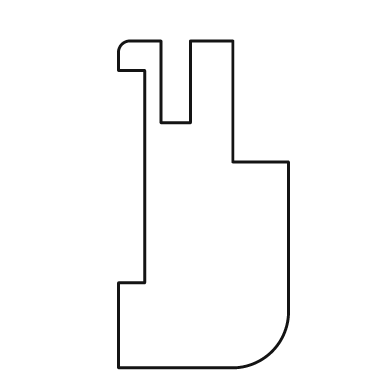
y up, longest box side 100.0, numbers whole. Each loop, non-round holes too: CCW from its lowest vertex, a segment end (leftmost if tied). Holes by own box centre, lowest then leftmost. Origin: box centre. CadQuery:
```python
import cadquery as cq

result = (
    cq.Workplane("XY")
    .moveTo(-26.0, -50.0)
    .lineTo(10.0, -50.0)
    .threePointArc((21.0, -45.0), (26.0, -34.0))
    .lineTo(26.0, 13.0)
    .lineTo(9.0, 13.0)
    .lineTo(9.0, 50.0)
    .lineTo(-4.0, 50.0)
    .lineTo(-4.0, 25.0)
    .lineTo(-13.0, 25.0)
    .lineTo(-13.0, 50.0)
    .lineTo(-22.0, 50.0)
    .threePointArc((-25.0, 49.0), (-26.0, 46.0))
    .lineTo(-26.0, 41.0)
    .lineTo(-18.0, 41.0)
    .lineTo(-18.0, -24.0)
    .lineTo(-26.0, -24.0)
    .close()
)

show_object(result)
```